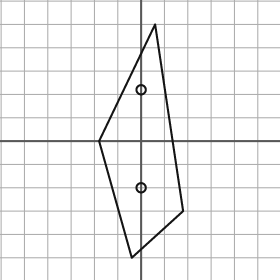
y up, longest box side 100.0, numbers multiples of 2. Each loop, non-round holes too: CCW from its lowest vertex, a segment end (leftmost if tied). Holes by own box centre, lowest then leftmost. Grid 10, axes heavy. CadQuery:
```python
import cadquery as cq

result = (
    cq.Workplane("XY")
    .moveTo(-4.0, -50.0)
    .lineTo(18.0, -30.0)
    .lineTo(6.0, 50.0)
    .lineTo(-18.0, 0.0)
    .close()
    .moveTo(0.0, -20.0)
    .circle(2.0)
    .moveTo(0.0, 22.0)
    .circle(2.0)
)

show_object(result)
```